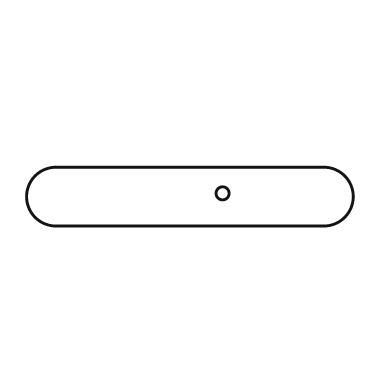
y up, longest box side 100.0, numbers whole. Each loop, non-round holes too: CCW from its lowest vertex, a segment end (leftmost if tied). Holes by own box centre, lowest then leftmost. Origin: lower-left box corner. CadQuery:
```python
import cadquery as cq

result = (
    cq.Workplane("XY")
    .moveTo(9.0, 0.0)
    .lineTo(91.0, 0.0)
    .threePointArc((100.0, 9.0), (91.0, 18.0))
    .lineTo(9.0, 18.0)
    .threePointArc((0.0, 9.0), (9.0, 0.0))
    .close()
    .moveTo(60.0, 10.0)
    .circle(2.0)
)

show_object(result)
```